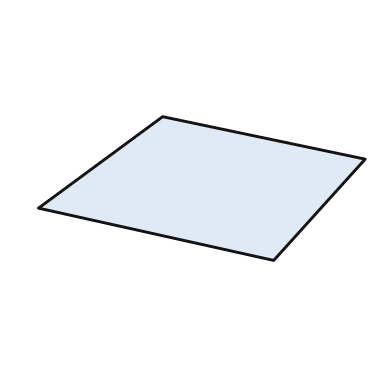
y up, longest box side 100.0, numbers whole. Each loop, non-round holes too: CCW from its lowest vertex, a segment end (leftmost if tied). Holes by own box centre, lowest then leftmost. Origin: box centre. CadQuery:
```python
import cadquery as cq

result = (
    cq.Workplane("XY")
    .moveTo(22.0, -22.0)
    .lineTo(50.0, 9.0)
    .lineTo(-12.0, 22.0)
    .lineTo(-50.0, -6.0)
    .close()
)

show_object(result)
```